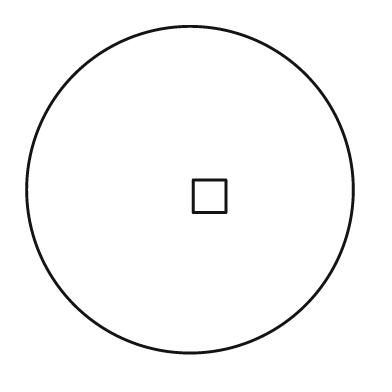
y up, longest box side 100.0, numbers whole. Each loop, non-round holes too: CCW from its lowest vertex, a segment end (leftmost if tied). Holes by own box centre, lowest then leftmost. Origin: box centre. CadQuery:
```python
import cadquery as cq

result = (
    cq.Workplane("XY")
    .moveTo(0.0, 0.0)
    .circle(50.0)
    .moveTo(1.0, -7.0)
    .lineTo(11.0, -7.0)
    .lineTo(11.0, 3.0)
    .lineTo(1.0, 3.0)
    .close()
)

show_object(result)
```